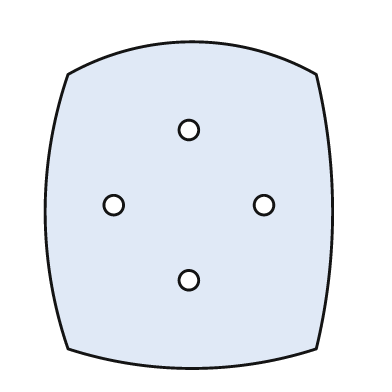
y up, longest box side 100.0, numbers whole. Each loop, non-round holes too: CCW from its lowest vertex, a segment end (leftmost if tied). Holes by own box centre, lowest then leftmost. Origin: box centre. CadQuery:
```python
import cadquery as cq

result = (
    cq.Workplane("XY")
    .moveTo(-37.0, -44.0)
    .threePointArc((1.0, -50.0), (39.0, -44.0))
    .threePointArc((44.0, -2.0), (39.0, 40.0))
    .threePointArc((1.0, 50.0), (-37.0, 40.0))
    .threePointArc((-44.0, -2.0), (-37.0, -44.0))
    .close()
    .moveTo(0.0, -23.0)
    .circle(3.0)
    .moveTo(-23.0, 0.0)
    .circle(3.0)
    .moveTo(23.0, 0.0)
    .circle(3.0)
    .moveTo(0.0, 23.0)
    .circle(3.0)
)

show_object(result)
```